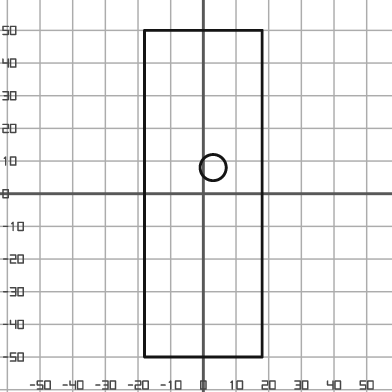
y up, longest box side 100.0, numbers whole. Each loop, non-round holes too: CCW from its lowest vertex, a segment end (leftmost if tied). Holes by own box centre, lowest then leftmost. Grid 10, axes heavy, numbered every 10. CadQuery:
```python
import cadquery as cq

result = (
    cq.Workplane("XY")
    .moveTo(-18.0, -50.0)
    .lineTo(18.0, -50.0)
    .lineTo(18.0, 50.0)
    .lineTo(-18.0, 50.0)
    .close()
    .moveTo(3.0, 8.0)
    .circle(4.0)
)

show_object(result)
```